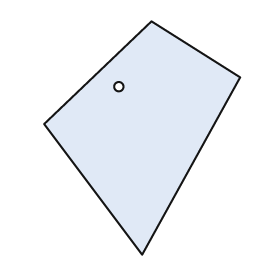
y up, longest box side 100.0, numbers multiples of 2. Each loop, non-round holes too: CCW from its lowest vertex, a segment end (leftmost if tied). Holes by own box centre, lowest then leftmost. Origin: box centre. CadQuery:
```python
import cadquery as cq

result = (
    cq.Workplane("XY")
    .moveTo(0.0, -50.0)
    .lineTo(42.0, 26.0)
    .lineTo(4.0, 50.0)
    .lineTo(-42.0, 6.0)
    .close()
    .moveTo(-10.0, 22.0)
    .circle(2.0)
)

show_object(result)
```